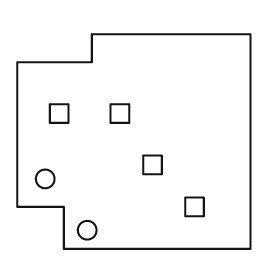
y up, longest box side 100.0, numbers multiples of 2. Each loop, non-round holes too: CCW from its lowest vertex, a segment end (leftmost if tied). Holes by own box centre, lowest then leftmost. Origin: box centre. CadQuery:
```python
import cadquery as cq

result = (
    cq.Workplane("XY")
    .moveTo(-30.0, -46.0)
    .lineTo(50.0, -46.0)
    .lineTo(50.0, 46.0)
    .lineTo(-18.0, 46.0)
    .lineTo(-18.0, 34.0)
    .lineTo(-50.0, 34.0)
    .lineTo(-50.0, -28.0)
    .lineTo(-30.0, -28.0)
    .close()
    .moveTo(-20.0, -38.0)
    .circle(4.0)
    .moveTo(22.0, -32.0)
    .lineTo(30.0, -32.0)
    .lineTo(30.0, -24.0)
    .lineTo(22.0, -24.0)
    .close()
    .moveTo(-38.0, -16.0)
    .circle(4.0)
    .moveTo(4.0, -14.0)
    .lineTo(12.0, -14.0)
    .lineTo(12.0, -6.0)
    .lineTo(4.0, -6.0)
    .close()
    .moveTo(-36.0, 8.0)
    .lineTo(-28.0, 8.0)
    .lineTo(-28.0, 16.0)
    .lineTo(-36.0, 16.0)
    .close()
    .moveTo(-10.0, 8.0)
    .lineTo(-2.0, 8.0)
    .lineTo(-2.0, 16.0)
    .lineTo(-10.0, 16.0)
    .close()
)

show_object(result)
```